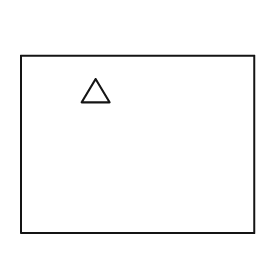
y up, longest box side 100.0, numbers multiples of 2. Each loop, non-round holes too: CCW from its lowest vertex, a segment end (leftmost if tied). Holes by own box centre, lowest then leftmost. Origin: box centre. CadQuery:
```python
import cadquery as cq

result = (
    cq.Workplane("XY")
    .moveTo(-50.0, -38.0)
    .lineTo(50.0, -38.0)
    .lineTo(50.0, 38.0)
    .lineTo(-50.0, 38.0)
    .close()
    .moveTo(-24.0, 18.0)
    .lineTo(-12.0, 18.0)
    .lineTo(-18.0, 28.0)
    .close()
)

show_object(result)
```